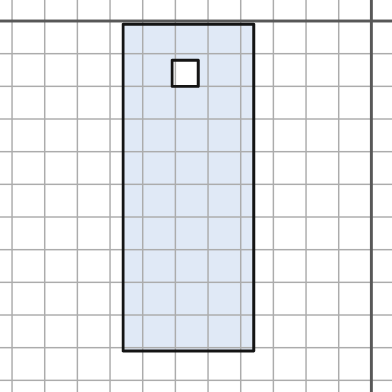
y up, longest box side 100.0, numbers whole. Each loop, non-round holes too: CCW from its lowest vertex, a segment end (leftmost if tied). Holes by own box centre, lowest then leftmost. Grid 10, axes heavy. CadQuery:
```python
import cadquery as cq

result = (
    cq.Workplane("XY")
    .moveTo(-76.0, -101.0)
    .lineTo(-36.0, -101.0)
    .lineTo(-36.0, -1.0)
    .lineTo(-76.0, -1.0)
    .close()
    .moveTo(-61.0, -20.0)
    .lineTo(-53.0, -20.0)
    .lineTo(-53.0, -12.0)
    .lineTo(-61.0, -12.0)
    .close()
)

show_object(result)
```